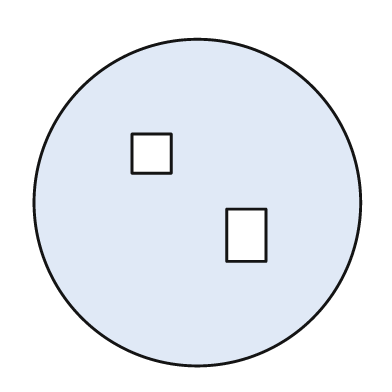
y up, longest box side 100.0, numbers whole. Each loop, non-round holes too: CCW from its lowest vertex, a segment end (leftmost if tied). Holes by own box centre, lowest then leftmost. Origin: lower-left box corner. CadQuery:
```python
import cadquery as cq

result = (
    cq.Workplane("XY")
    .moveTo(50.0, 50.0)
    .circle(50.0)
    .moveTo(59.0, 32.0)
    .lineTo(71.0, 32.0)
    .lineTo(71.0, 48.0)
    .lineTo(59.0, 48.0)
    .close()
    .moveTo(30.0, 59.0)
    .lineTo(42.0, 59.0)
    .lineTo(42.0, 71.0)
    .lineTo(30.0, 71.0)
    .close()
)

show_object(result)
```